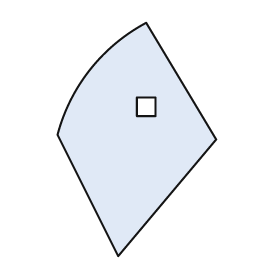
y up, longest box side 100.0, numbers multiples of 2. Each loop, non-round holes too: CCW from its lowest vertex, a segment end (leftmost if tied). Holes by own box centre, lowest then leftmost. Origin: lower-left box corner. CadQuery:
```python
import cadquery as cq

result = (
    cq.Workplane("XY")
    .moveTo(26.0, 0.0)
    .lineTo(68.0, 50.0)
    .lineTo(38.0, 100.0)
    .threePointArc((14.0, 80.0), (0.0, 52.0))
    .close()
    .moveTo(34.0, 60.0)
    .lineTo(42.0, 60.0)
    .lineTo(42.0, 68.0)
    .lineTo(34.0, 68.0)
    .close()
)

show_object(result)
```